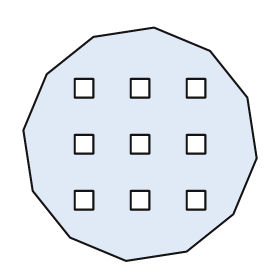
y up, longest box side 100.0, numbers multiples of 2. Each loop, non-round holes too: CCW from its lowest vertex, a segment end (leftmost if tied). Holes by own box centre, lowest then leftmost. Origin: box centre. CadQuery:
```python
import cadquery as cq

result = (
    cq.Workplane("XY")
    .moveTo(-6.0, -50.0)
    .lineTo(20.0, -46.0)
    .lineTo(40.0, -30.0)
    .lineTo(50.0, -6.0)
    .lineTo(46.0, 20.0)
    .lineTo(30.0, 40.0)
    .lineTo(6.0, 50.0)
    .lineTo(-20.0, 46.0)
    .lineTo(-40.0, 30.0)
    .lineTo(-50.0, 6.0)
    .lineTo(-46.0, -20.0)
    .lineTo(-30.0, -40.0)
    .close()
    .moveTo(-28.0, -28.0)
    .lineTo(-20.0, -28.0)
    .lineTo(-20.0, -20.0)
    .lineTo(-28.0, -20.0)
    .close()
    .moveTo(-4.0, -28.0)
    .lineTo(4.0, -28.0)
    .lineTo(4.0, -20.0)
    .lineTo(-4.0, -20.0)
    .close()
    .moveTo(20.0, -28.0)
    .lineTo(28.0, -28.0)
    .lineTo(28.0, -20.0)
    .lineTo(20.0, -20.0)
    .close()
    .moveTo(-28.0, -4.0)
    .lineTo(-20.0, -4.0)
    .lineTo(-20.0, 4.0)
    .lineTo(-28.0, 4.0)
    .close()
    .moveTo(-4.0, -4.0)
    .lineTo(4.0, -4.0)
    .lineTo(4.0, 4.0)
    .lineTo(-4.0, 4.0)
    .close()
    .moveTo(20.0, -4.0)
    .lineTo(28.0, -4.0)
    .lineTo(28.0, 4.0)
    .lineTo(20.0, 4.0)
    .close()
    .moveTo(-28.0, 20.0)
    .lineTo(-20.0, 20.0)
    .lineTo(-20.0, 28.0)
    .lineTo(-28.0, 28.0)
    .close()
    .moveTo(-4.0, 20.0)
    .lineTo(4.0, 20.0)
    .lineTo(4.0, 28.0)
    .lineTo(-4.0, 28.0)
    .close()
    .moveTo(20.0, 20.0)
    .lineTo(28.0, 20.0)
    .lineTo(28.0, 28.0)
    .lineTo(20.0, 28.0)
    .close()
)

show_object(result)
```